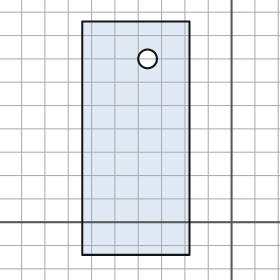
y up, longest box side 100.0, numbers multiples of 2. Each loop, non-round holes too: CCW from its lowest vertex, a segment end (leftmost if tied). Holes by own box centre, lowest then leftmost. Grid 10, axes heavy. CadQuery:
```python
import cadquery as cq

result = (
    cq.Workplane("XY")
    .moveTo(-64.0, -14.0)
    .lineTo(-18.0, -14.0)
    .lineTo(-18.0, 86.0)
    .lineTo(-64.0, 86.0)
    .close()
    .moveTo(-36.0, 70.0)
    .circle(4.0)
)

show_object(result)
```